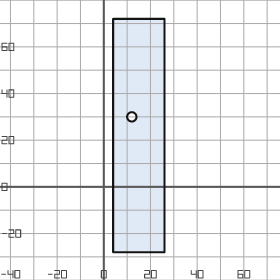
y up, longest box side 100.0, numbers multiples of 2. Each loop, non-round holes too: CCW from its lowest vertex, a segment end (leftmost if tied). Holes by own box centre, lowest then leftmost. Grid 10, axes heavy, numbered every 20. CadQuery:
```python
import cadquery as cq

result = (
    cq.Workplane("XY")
    .moveTo(4.0, -28.0)
    .lineTo(26.0, -28.0)
    .lineTo(26.0, 72.0)
    .lineTo(4.0, 72.0)
    .close()
    .moveTo(12.0, 30.0)
    .circle(2.0)
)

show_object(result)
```